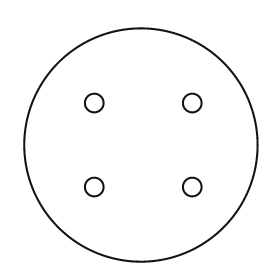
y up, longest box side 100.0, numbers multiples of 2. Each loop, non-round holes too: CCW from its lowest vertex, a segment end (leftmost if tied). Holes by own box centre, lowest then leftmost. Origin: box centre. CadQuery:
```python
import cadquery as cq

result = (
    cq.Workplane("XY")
    .moveTo(0.0, 0.0)
    .circle(50.0)
    .moveTo(-20.0, -18.0)
    .circle(4.0)
    .moveTo(22.0, -18.0)
    .circle(4.0)
    .moveTo(-20.0, 18.0)
    .circle(4.0)
    .moveTo(22.0, 18.0)
    .circle(4.0)
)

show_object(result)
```